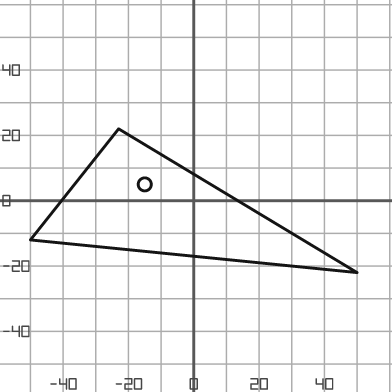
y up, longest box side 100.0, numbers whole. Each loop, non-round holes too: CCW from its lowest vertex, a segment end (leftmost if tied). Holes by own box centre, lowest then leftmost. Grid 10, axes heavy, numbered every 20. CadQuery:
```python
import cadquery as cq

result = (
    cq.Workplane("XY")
    .moveTo(50.0, -22.0)
    .lineTo(-23.0, 22.0)
    .lineTo(-50.0, -12.0)
    .close()
    .moveTo(-15.0, 5.0)
    .circle(2.0)
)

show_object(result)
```